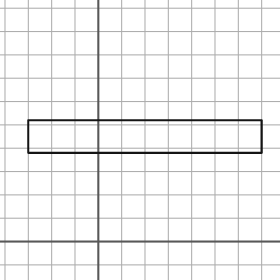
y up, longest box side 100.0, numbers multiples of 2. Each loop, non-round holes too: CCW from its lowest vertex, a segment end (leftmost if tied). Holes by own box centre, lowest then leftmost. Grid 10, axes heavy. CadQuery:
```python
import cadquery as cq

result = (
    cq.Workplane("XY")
    .moveTo(-30.0, 38.0)
    .lineTo(70.0, 38.0)
    .lineTo(70.0, 52.0)
    .lineTo(-30.0, 52.0)
    .close()
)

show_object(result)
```